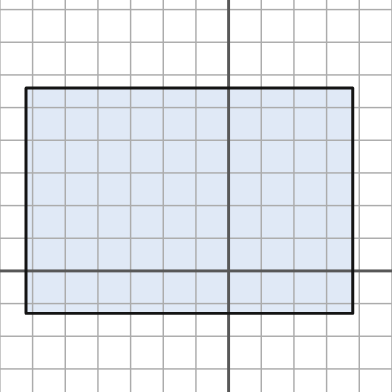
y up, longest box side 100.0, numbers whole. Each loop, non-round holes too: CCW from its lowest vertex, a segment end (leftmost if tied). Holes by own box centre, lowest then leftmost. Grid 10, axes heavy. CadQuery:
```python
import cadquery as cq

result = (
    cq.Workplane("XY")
    .moveTo(-62.0, -13.0)
    .lineTo(38.0, -13.0)
    .lineTo(38.0, 56.0)
    .lineTo(-62.0, 56.0)
    .close()
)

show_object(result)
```